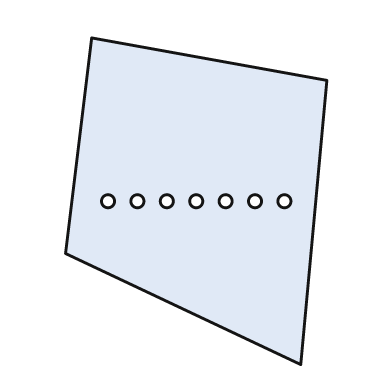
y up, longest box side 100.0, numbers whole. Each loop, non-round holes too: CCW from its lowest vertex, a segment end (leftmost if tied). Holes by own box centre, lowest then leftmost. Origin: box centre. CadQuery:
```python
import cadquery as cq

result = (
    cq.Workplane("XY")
    .moveTo(32.0, -50.0)
    .lineTo(40.0, 37.0)
    .lineTo(-32.0, 50.0)
    .lineTo(-40.0, -16.0)
    .close()
    .moveTo(-27.0, 0.0)
    .circle(2.0)
    .moveTo(-18.0, 0.0)
    .circle(2.0)
    .moveTo(-9.0, 0.0)
    .circle(2.0)
    .moveTo(0.0, 0.0)
    .circle(2.0)
    .moveTo(9.0, 0.0)
    .circle(2.0)
    .moveTo(18.0, 0.0)
    .circle(2.0)
    .moveTo(27.0, 0.0)
    .circle(2.0)
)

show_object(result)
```